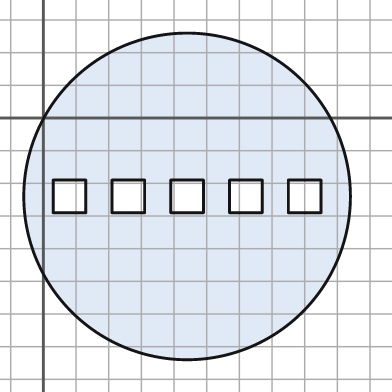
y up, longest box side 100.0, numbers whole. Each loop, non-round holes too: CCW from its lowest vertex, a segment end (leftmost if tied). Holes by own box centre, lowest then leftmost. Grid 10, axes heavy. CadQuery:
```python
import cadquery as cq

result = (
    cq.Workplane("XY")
    .moveTo(44.0, -24.0)
    .circle(50.0)
    .moveTo(3.0, -29.0)
    .lineTo(13.0, -29.0)
    .lineTo(13.0, -19.0)
    .lineTo(3.0, -19.0)
    .close()
    .moveTo(21.0, -29.0)
    .lineTo(31.0, -29.0)
    .lineTo(31.0, -19.0)
    .lineTo(21.0, -19.0)
    .close()
    .moveTo(39.0, -29.0)
    .lineTo(49.0, -29.0)
    .lineTo(49.0, -19.0)
    .lineTo(39.0, -19.0)
    .close()
    .moveTo(57.0, -29.0)
    .lineTo(67.0, -29.0)
    .lineTo(67.0, -19.0)
    .lineTo(57.0, -19.0)
    .close()
    .moveTo(75.0, -29.0)
    .lineTo(85.0, -29.0)
    .lineTo(85.0, -19.0)
    .lineTo(75.0, -19.0)
    .close()
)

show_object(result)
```